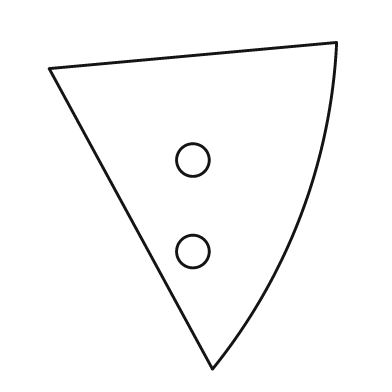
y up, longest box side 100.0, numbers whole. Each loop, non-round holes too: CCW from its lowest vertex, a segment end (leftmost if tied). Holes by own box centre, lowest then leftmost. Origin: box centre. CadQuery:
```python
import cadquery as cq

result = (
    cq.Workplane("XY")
    .moveTo(6.0, -50.0)
    .threePointArc((33.0, -3.0), (44.0, 50.0))
    .lineTo(-44.0, 42.0)
    .close()
    .moveTo(0.0, -14.0)
    .circle(5.0)
    .moveTo(0.0, 14.0)
    .circle(5.0)
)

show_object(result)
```